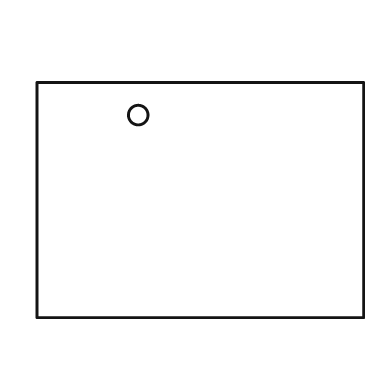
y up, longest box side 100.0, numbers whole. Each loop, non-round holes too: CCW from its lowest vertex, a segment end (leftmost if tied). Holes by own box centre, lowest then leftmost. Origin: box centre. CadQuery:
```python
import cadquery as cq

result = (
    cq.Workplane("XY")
    .moveTo(-50.0, -36.0)
    .lineTo(50.0, -36.0)
    .lineTo(50.0, 36.0)
    .lineTo(-50.0, 36.0)
    .close()
    .moveTo(-19.0, 26.0)
    .circle(3.0)
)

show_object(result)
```